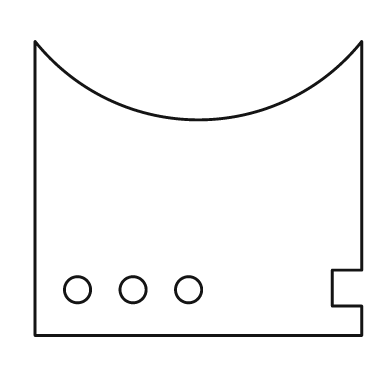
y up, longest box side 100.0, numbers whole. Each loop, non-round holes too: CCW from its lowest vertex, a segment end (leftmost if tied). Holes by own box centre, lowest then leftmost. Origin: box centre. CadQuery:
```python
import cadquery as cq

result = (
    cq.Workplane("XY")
    .moveTo(-50.0, -45.0)
    .lineTo(50.0, -45.0)
    .lineTo(50.0, -36.0)
    .lineTo(41.0, -36.0)
    .lineTo(41.0, -25.0)
    .lineTo(50.0, -25.0)
    .lineTo(50.0, 45.0)
    .threePointArc((0.0, 21.0), (-50.0, 45.0))
    .close()
    .moveTo(-37.0, -31.0)
    .circle(4.0)
    .moveTo(-20.0, -31.0)
    .circle(4.0)
    .moveTo(-3.0, -31.0)
    .circle(4.0)
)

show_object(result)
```